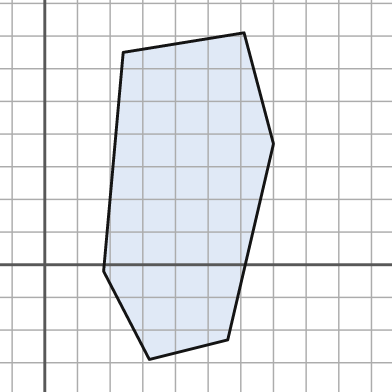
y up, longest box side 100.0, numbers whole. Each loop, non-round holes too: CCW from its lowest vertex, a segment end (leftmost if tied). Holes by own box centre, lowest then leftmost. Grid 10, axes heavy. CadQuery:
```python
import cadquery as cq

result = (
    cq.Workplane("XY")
    .moveTo(32.0, -29.0)
    .lineTo(56.0, -23.0)
    .lineTo(70.0, 37.0)
    .lineTo(61.0, 71.0)
    .lineTo(24.0, 65.0)
    .lineTo(18.0, -2.0)
    .close()
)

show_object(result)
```